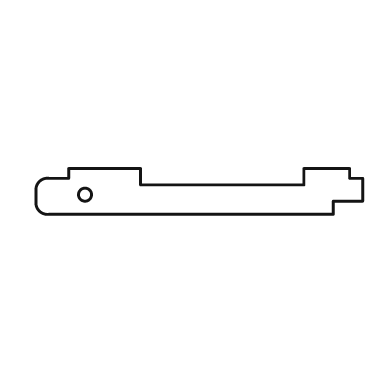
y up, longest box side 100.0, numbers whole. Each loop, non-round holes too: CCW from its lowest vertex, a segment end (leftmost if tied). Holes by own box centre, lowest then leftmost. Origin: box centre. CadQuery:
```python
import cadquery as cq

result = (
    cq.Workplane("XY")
    .moveTo(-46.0, -7.0)
    .lineTo(41.0, -7.0)
    .lineTo(41.0, -3.0)
    .lineTo(50.0, -3.0)
    .lineTo(50.0, 4.0)
    .lineTo(46.0, 4.0)
    .lineTo(46.0, 7.0)
    .lineTo(32.0, 7.0)
    .lineTo(32.0, 2.0)
    .lineTo(-18.0, 2.0)
    .lineTo(-18.0, 7.0)
    .lineTo(-40.0, 7.0)
    .lineTo(-40.0, 4.0)
    .lineTo(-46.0, 4.0)
    .threePointArc((-49.0, 3.0), (-50.0, 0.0))
    .lineTo(-50.0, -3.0)
    .threePointArc((-49.0, -6.0), (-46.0, -7.0))
    .close()
    .moveTo(-35.0, -1.0)
    .circle(2.0)
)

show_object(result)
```